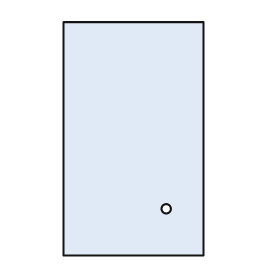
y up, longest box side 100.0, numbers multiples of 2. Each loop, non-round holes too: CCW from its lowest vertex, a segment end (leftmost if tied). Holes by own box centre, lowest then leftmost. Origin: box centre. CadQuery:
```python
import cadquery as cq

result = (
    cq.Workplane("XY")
    .moveTo(-30.0, -50.0)
    .lineTo(30.0, -50.0)
    .lineTo(30.0, 50.0)
    .lineTo(-30.0, 50.0)
    .close()
    .moveTo(14.0, -30.0)
    .circle(2.0)
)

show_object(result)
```